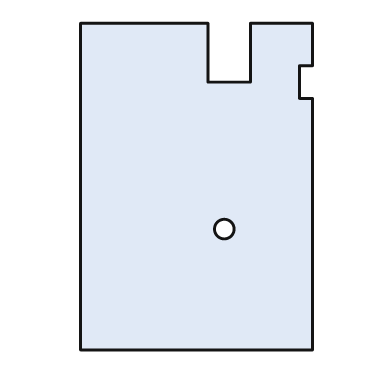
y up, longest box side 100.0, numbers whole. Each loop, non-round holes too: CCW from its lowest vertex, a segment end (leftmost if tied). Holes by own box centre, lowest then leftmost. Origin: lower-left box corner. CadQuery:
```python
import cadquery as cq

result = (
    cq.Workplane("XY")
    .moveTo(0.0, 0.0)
    .lineTo(71.0, 0.0)
    .lineTo(71.0, 77.0)
    .lineTo(67.0, 77.0)
    .lineTo(67.0, 87.0)
    .lineTo(71.0, 87.0)
    .lineTo(71.0, 100.0)
    .lineTo(52.0, 100.0)
    .lineTo(52.0, 82.0)
    .lineTo(39.0, 82.0)
    .lineTo(39.0, 100.0)
    .lineTo(0.0, 100.0)
    .close()
    .moveTo(44.0, 37.0)
    .circle(3.0)
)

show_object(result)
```